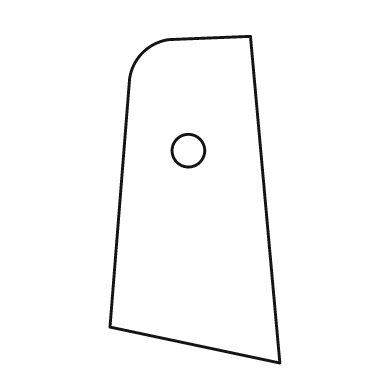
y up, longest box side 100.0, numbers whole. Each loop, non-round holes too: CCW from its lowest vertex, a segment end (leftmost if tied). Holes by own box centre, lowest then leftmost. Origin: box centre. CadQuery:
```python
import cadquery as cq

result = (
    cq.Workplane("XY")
    .moveTo(26.0, -50.0)
    .lineTo(17.0, 50.0)
    .lineTo(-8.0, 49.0)
    .threePointArc((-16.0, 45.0), (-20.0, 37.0))
    .lineTo(-26.0, -39.0)
    .close()
    .moveTo(-2.0, 15.0)
    .circle(5.0)
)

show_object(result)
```